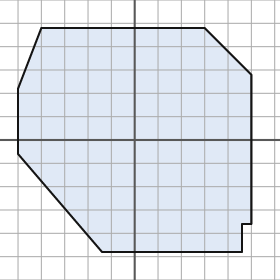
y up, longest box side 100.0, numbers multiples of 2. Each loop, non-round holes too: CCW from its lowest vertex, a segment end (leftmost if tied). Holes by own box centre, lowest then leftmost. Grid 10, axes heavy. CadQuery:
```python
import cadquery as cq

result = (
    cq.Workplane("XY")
    .moveTo(-14.0, -48.0)
    .lineTo(46.0, -48.0)
    .lineTo(46.0, -36.0)
    .lineTo(50.0, -36.0)
    .lineTo(50.0, 28.0)
    .lineTo(30.0, 48.0)
    .lineTo(-40.0, 48.0)
    .lineTo(-50.0, 22.0)
    .lineTo(-50.0, -6.0)
    .close()
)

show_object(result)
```